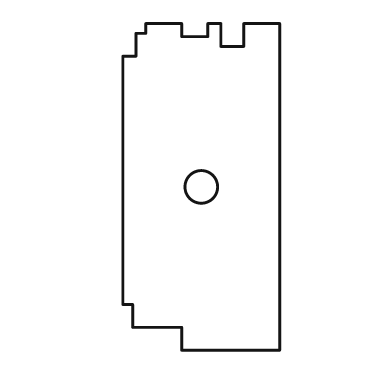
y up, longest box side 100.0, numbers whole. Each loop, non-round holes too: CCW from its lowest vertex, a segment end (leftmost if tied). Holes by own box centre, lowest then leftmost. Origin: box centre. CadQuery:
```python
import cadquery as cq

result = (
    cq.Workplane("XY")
    .moveTo(-6.0, -50.0)
    .lineTo(24.0, -50.0)
    .lineTo(24.0, 50.0)
    .lineTo(13.0, 50.0)
    .lineTo(13.0, 43.0)
    .lineTo(6.0, 43.0)
    .lineTo(6.0, 50.0)
    .lineTo(2.0, 50.0)
    .lineTo(2.0, 46.0)
    .lineTo(-6.0, 46.0)
    .lineTo(-6.0, 50.0)
    .lineTo(-17.0, 50.0)
    .lineTo(-17.0, 47.0)
    .lineTo(-20.0, 47.0)
    .lineTo(-20.0, 40.0)
    .lineTo(-24.0, 40.0)
    .lineTo(-24.0, -36.0)
    .lineTo(-21.0, -36.0)
    .lineTo(-21.0, -43.0)
    .lineTo(-6.0, -43.0)
    .close()
    .moveTo(0.0, 0.0)
    .circle(5.0)
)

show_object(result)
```